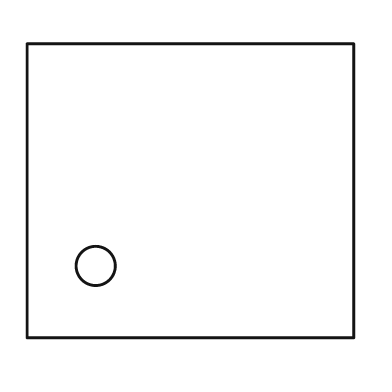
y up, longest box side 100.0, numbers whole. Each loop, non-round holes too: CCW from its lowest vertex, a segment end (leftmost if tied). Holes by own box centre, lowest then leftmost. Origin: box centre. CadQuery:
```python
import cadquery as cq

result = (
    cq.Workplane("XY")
    .moveTo(-50.0, -45.0)
    .lineTo(50.0, -45.0)
    .lineTo(50.0, 45.0)
    .lineTo(-50.0, 45.0)
    .close()
    .moveTo(-29.0, -23.0)
    .circle(6.0)
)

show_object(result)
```